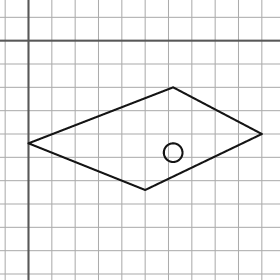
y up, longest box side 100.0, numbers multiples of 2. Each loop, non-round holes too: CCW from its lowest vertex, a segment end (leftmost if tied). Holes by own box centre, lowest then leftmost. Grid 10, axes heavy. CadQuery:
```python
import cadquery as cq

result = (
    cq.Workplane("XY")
    .moveTo(50.0, -64.0)
    .lineTo(100.0, -40.0)
    .lineTo(62.0, -20.0)
    .lineTo(0.0, -44.0)
    .close()
    .moveTo(62.0, -48.0)
    .circle(4.0)
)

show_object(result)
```